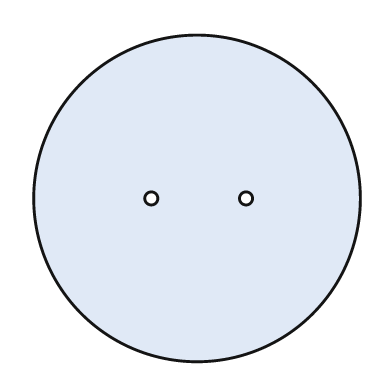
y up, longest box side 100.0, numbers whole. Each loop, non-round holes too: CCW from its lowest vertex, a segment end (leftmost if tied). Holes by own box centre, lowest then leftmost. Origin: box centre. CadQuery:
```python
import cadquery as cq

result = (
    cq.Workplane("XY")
    .moveTo(0.0, 0.0)
    .circle(50.0)
    .moveTo(-14.0, 0.0)
    .circle(2.0)
    .moveTo(15.0, 0.0)
    .circle(2.0)
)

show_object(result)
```